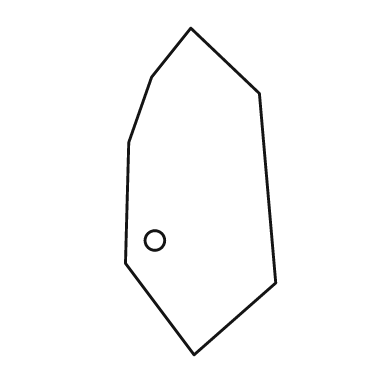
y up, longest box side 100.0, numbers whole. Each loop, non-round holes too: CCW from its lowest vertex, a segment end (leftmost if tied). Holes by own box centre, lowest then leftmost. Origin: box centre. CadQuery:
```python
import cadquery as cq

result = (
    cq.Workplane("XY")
    .moveTo(-2.0, -50.0)
    .lineTo(23.0, -28.0)
    .lineTo(18.0, 30.0)
    .lineTo(-3.0, 50.0)
    .lineTo(-15.0, 35.0)
    .lineTo(-22.0, 15.0)
    .lineTo(-23.0, -22.0)
    .close()
    .moveTo(-14.0, -15.0)
    .circle(3.0)
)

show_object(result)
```